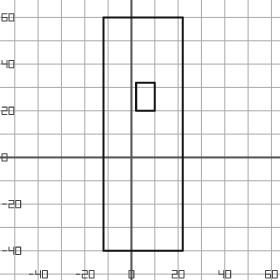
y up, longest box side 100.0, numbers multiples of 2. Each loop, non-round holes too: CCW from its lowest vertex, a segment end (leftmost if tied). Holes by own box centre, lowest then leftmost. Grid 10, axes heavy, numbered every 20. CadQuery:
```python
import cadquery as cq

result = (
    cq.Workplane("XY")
    .moveTo(-12.0, -40.0)
    .lineTo(22.0, -40.0)
    .lineTo(22.0, 60.0)
    .lineTo(-12.0, 60.0)
    .close()
    .moveTo(2.0, 20.0)
    .lineTo(10.0, 20.0)
    .lineTo(10.0, 32.0)
    .lineTo(2.0, 32.0)
    .close()
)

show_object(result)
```